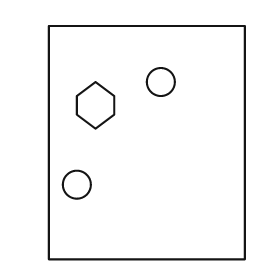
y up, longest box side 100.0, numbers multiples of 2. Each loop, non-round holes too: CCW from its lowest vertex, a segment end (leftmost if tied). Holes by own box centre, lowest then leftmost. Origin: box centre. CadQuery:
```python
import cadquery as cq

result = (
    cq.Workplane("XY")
    .moveTo(-42.0, -50.0)
    .lineTo(42.0, -50.0)
    .lineTo(42.0, 50.0)
    .lineTo(-42.0, 50.0)
    .close()
    .moveTo(-30.0, -18.0)
    .circle(6.0)
    .moveTo(-22.0, 6.0)
    .lineTo(-14.0, 12.0)
    .lineTo(-14.0, 20.0)
    .lineTo(-22.0, 26.0)
    .lineTo(-30.0, 20.0)
    .lineTo(-30.0, 12.0)
    .close()
    .moveTo(6.0, 26.0)
    .circle(6.0)
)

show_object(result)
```